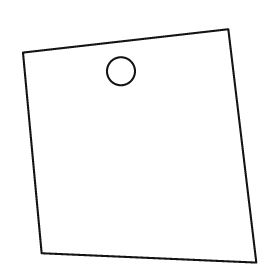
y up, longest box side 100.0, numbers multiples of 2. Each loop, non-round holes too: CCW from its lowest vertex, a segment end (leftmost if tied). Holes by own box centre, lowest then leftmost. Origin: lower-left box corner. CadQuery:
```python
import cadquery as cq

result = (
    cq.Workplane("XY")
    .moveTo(100.0, 0.0)
    .lineTo(88.0, 100.0)
    .lineTo(0.0, 90.0)
    .lineTo(8.0, 4.0)
    .close()
    .moveTo(42.0, 82.0)
    .circle(6.0)
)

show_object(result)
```